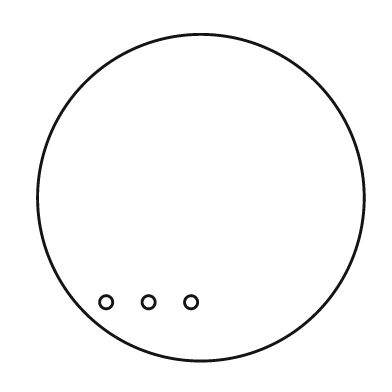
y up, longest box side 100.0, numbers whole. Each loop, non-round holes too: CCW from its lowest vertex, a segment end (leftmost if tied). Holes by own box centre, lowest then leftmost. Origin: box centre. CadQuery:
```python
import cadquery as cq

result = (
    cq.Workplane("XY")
    .moveTo(0.0, 0.0)
    .circle(50.0)
    .moveTo(-29.0, -32.0)
    .circle(2.0)
    .moveTo(-16.0, -32.0)
    .circle(2.0)
    .moveTo(-3.0, -32.0)
    .circle(2.0)
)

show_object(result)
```